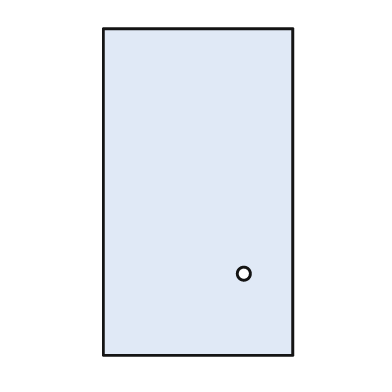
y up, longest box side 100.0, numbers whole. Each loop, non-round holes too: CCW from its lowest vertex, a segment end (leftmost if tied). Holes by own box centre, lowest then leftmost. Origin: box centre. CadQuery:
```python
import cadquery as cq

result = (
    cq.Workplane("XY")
    .moveTo(-29.0, -50.0)
    .lineTo(29.0, -50.0)
    .lineTo(29.0, 50.0)
    .lineTo(-29.0, 50.0)
    .close()
    .moveTo(14.0, -25.0)
    .circle(2.0)
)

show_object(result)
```